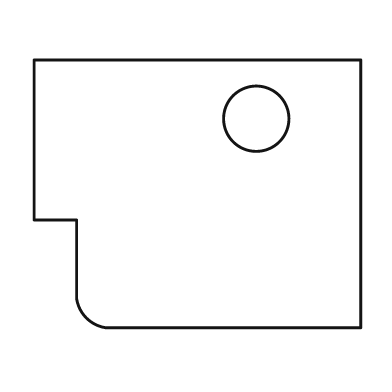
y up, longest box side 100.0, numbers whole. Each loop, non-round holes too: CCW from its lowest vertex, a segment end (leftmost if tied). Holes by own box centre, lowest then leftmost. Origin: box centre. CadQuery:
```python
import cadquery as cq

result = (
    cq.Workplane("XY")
    .moveTo(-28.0, -41.0)
    .lineTo(50.0, -41.0)
    .lineTo(50.0, 41.0)
    .lineTo(-50.0, 41.0)
    .lineTo(-50.0, -8.0)
    .lineTo(-37.0, -8.0)
    .lineTo(-37.0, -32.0)
    .threePointArc((-34.0, -38.0), (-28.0, -41.0))
    .close()
    .moveTo(18.0, 23.0)
    .circle(10.0)
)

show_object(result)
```